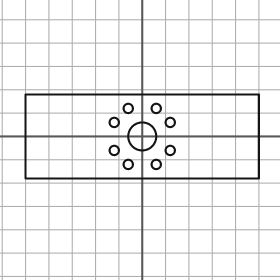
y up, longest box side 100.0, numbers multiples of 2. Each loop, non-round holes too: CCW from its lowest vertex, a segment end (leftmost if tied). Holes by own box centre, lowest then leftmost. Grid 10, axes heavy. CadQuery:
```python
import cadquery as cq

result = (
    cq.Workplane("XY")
    .moveTo(-50.0, -18.0)
    .lineTo(50.0, -18.0)
    .lineTo(50.0, 18.0)
    .lineTo(-50.0, 18.0)
    .close()
    .moveTo(-6.0, -12.0)
    .circle(2.0)
    .moveTo(6.0, -12.0)
    .circle(2.0)
    .moveTo(-12.0, -6.0)
    .circle(2.0)
    .moveTo(12.0, -6.0)
    .circle(2.0)
    .moveTo(0.0, 0.0)
    .circle(6.0)
    .moveTo(-12.0, 6.0)
    .circle(2.0)
    .moveTo(12.0, 6.0)
    .circle(2.0)
    .moveTo(-6.0, 12.0)
    .circle(2.0)
    .moveTo(6.0, 12.0)
    .circle(2.0)
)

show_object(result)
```